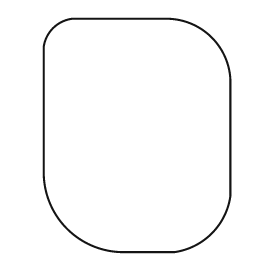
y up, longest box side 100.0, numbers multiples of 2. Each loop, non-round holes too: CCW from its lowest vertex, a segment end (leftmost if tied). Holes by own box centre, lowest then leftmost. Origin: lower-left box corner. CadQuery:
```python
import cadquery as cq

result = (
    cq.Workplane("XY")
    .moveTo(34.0, 0.0)
    .lineTo(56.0, 0.0)
    .threePointArc((72.0, 8.0), (80.0, 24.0))
    .lineTo(80.0, 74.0)
    .threePointArc((72.0, 92.0), (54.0, 100.0))
    .lineTo(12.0, 100.0)
    .threePointArc((4.0, 96.0), (0.0, 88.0))
    .lineTo(0.0, 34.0)
    .threePointArc((10.0, 10.0), (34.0, 0.0))
    .close()
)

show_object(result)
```